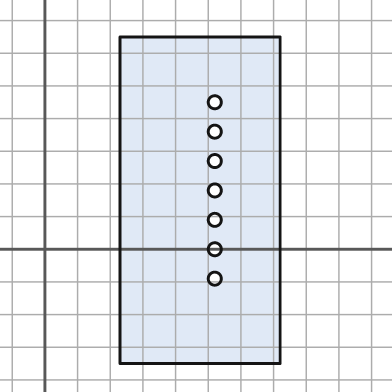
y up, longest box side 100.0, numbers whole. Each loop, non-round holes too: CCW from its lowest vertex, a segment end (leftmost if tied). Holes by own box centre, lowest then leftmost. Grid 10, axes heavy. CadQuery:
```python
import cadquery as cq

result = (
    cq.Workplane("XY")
    .moveTo(23.0, -35.0)
    .lineTo(72.0, -35.0)
    .lineTo(72.0, 65.0)
    .lineTo(23.0, 65.0)
    .close()
    .moveTo(52.0, -9.0)
    .circle(2.0)
    .moveTo(52.0, 0.0)
    .circle(2.0)
    .moveTo(52.0, 9.0)
    .circle(2.0)
    .moveTo(52.0, 18.0)
    .circle(2.0)
    .moveTo(52.0, 27.0)
    .circle(2.0)
    .moveTo(52.0, 36.0)
    .circle(2.0)
    .moveTo(52.0, 45.0)
    .circle(2.0)
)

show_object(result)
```